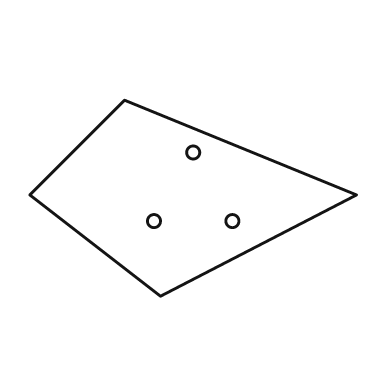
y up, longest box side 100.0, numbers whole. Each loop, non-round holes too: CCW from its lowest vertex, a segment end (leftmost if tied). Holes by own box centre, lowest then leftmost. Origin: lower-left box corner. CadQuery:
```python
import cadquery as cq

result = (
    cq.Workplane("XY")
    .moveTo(40.0, 0.0)
    .lineTo(100.0, 31.0)
    .lineTo(29.0, 60.0)
    .lineTo(0.0, 31.0)
    .close()
    .moveTo(38.0, 23.0)
    .circle(2.0)
    .moveTo(62.0, 23.0)
    .circle(2.0)
    .moveTo(50.0, 44.0)
    .circle(2.0)
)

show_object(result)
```